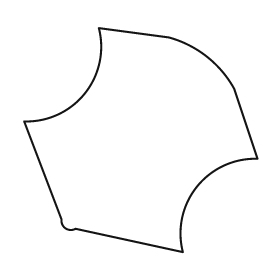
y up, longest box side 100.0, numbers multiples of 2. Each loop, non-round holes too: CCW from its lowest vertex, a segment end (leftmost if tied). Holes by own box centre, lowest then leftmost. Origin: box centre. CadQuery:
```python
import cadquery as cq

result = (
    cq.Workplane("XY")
    .moveTo(18.0, -48.0)
    .threePointArc((24.0, -20.0), (50.0, -8.0))
    .lineTo(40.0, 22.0)
    .threePointArc((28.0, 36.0), (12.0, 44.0))
    .lineTo(-18.0, 48.0)
    .threePointArc((-24.0, 20.0), (-50.0, 8.0))
    .lineTo(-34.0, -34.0)
    .threePointArc((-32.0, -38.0), (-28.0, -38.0))
    .close()
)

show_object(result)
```